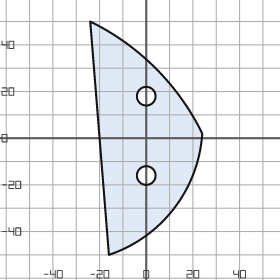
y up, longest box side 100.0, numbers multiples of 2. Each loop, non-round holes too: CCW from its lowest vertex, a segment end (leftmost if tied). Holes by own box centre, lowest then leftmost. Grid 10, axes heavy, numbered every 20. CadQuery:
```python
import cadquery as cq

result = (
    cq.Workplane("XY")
    .moveTo(-16.0, -50.0)
    .threePointArc((12.0, -30.0), (24.0, 2.0))
    .threePointArc((4.0, 30.0), (-24.0, 50.0))
    .close()
    .moveTo(0.0, -16.0)
    .circle(4.0)
    .moveTo(0.0, 18.0)
    .circle(4.0)
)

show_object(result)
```